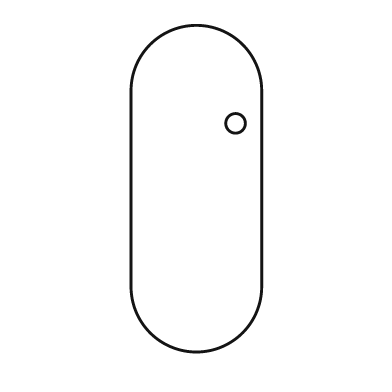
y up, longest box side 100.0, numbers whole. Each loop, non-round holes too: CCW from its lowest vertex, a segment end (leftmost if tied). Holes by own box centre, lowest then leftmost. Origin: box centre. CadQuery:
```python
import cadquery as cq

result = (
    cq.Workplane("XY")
    .moveTo(-20.0, -30.0)
    .threePointArc((0.0, -50.0), (20.0, -30.0))
    .lineTo(20.0, 30.0)
    .threePointArc((0.0, 50.0), (-20.0, 30.0))
    .close()
    .moveTo(12.0, 20.0)
    .circle(3.0)
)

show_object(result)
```